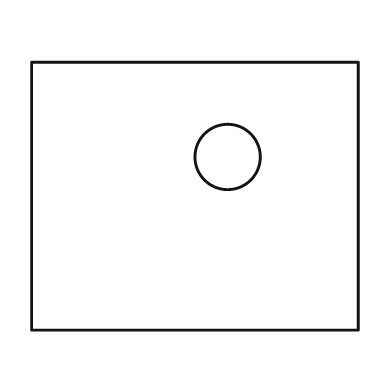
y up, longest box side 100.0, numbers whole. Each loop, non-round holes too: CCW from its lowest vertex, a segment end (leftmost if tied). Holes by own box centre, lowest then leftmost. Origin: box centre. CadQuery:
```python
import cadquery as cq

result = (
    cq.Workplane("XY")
    .moveTo(-50.0, -41.0)
    .lineTo(50.0, -41.0)
    .lineTo(50.0, 41.0)
    .lineTo(-50.0, 41.0)
    .close()
    .moveTo(10.0, 12.0)
    .circle(10.0)
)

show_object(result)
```